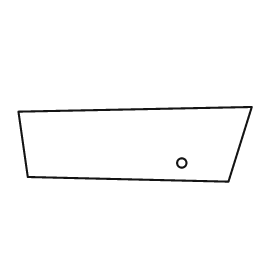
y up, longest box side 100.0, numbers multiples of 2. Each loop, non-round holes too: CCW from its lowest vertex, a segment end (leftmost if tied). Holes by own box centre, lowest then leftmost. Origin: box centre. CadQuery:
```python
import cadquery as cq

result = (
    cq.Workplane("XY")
    .moveTo(40.0, -16.0)
    .lineTo(50.0, 16.0)
    .lineTo(-50.0, 14.0)
    .lineTo(-46.0, -14.0)
    .close()
    .moveTo(20.0, -8.0)
    .circle(2.0)
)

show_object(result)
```